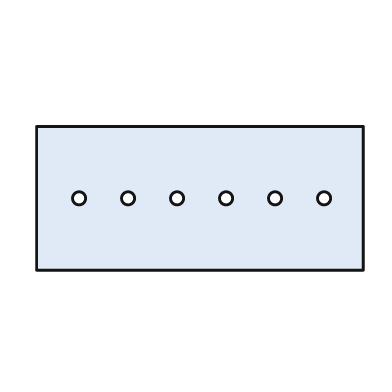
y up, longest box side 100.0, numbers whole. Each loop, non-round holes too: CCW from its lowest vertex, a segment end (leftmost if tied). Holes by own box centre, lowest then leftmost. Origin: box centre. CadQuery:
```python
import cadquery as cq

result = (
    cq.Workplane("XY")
    .moveTo(-50.0, -22.0)
    .lineTo(50.0, -22.0)
    .lineTo(50.0, 22.0)
    .lineTo(-50.0, 22.0)
    .close()
    .moveTo(-37.0, 0.0)
    .circle(2.0)
    .moveTo(-22.0, 0.0)
    .circle(2.0)
    .moveTo(-7.0, 0.0)
    .circle(2.0)
    .moveTo(8.0, 0.0)
    .circle(2.0)
    .moveTo(23.0, 0.0)
    .circle(2.0)
    .moveTo(38.0, 0.0)
    .circle(2.0)
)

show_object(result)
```